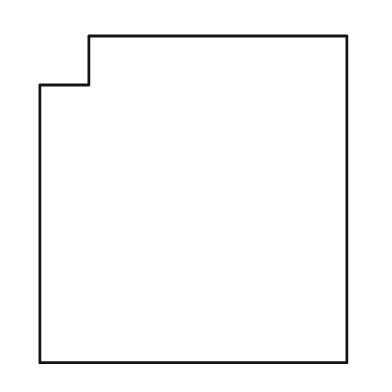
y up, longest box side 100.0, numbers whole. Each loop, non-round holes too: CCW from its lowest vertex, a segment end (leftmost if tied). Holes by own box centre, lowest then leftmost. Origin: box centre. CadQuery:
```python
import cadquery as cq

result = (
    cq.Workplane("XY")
    .moveTo(-47.0, -50.0)
    .lineTo(47.0, -50.0)
    .lineTo(47.0, 50.0)
    .lineTo(-32.0, 50.0)
    .lineTo(-32.0, 35.0)
    .lineTo(-47.0, 35.0)
    .close()
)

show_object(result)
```